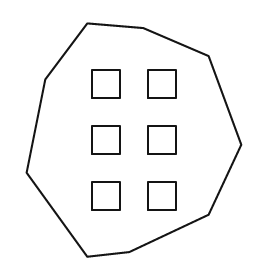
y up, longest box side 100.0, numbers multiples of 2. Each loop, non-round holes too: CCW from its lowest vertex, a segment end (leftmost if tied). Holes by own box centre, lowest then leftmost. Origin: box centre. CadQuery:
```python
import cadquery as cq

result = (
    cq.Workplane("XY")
    .moveTo(-20.0, -50.0)
    .lineTo(-2.0, -48.0)
    .lineTo(32.0, -32.0)
    .lineTo(46.0, -2.0)
    .lineTo(32.0, 36.0)
    .lineTo(4.0, 48.0)
    .lineTo(-20.0, 50.0)
    .lineTo(-38.0, 26.0)
    .lineTo(-46.0, -14.0)
    .close()
    .moveTo(-18.0, -30.0)
    .lineTo(-6.0, -30.0)
    .lineTo(-6.0, -18.0)
    .lineTo(-18.0, -18.0)
    .close()
    .moveTo(6.0, -30.0)
    .lineTo(18.0, -30.0)
    .lineTo(18.0, -18.0)
    .lineTo(6.0, -18.0)
    .close()
    .moveTo(-18.0, -6.0)
    .lineTo(-6.0, -6.0)
    .lineTo(-6.0, 6.0)
    .lineTo(-18.0, 6.0)
    .close()
    .moveTo(6.0, -6.0)
    .lineTo(18.0, -6.0)
    .lineTo(18.0, 6.0)
    .lineTo(6.0, 6.0)
    .close()
    .moveTo(-18.0, 18.0)
    .lineTo(-6.0, 18.0)
    .lineTo(-6.0, 30.0)
    .lineTo(-18.0, 30.0)
    .close()
    .moveTo(6.0, 18.0)
    .lineTo(18.0, 18.0)
    .lineTo(18.0, 30.0)
    .lineTo(6.0, 30.0)
    .close()
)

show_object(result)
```